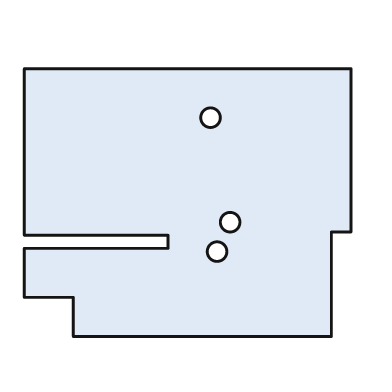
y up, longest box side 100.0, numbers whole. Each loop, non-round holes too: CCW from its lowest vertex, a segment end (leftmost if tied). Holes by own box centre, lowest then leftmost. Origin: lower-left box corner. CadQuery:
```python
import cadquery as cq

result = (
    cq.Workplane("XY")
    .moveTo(15.0, 0.0)
    .lineTo(94.0, 0.0)
    .lineTo(94.0, 32.0)
    .lineTo(100.0, 32.0)
    .lineTo(100.0, 82.0)
    .lineTo(0.0, 82.0)
    .lineTo(0.0, 31.0)
    .lineTo(44.0, 31.0)
    .lineTo(44.0, 27.0)
    .lineTo(0.0, 27.0)
    .lineTo(0.0, 12.0)
    .lineTo(15.0, 12.0)
    .close()
    .moveTo(59.0, 26.0)
    .circle(3.0)
    .moveTo(63.0, 35.0)
    .circle(3.0)
    .moveTo(57.0, 67.0)
    .circle(3.0)
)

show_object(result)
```